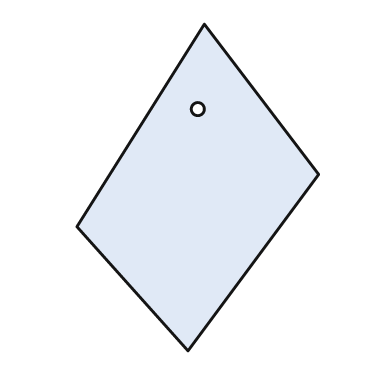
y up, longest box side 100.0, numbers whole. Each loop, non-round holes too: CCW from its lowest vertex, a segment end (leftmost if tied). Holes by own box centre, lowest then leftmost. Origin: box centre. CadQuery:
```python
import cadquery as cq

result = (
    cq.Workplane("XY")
    .moveTo(-3.0, -50.0)
    .lineTo(37.0, 4.0)
    .lineTo(2.0, 50.0)
    .lineTo(-37.0, -12.0)
    .close()
    .moveTo(0.0, 24.0)
    .circle(2.0)
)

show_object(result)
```